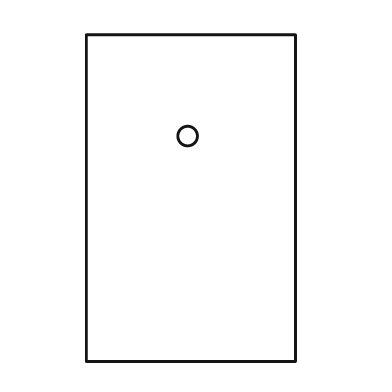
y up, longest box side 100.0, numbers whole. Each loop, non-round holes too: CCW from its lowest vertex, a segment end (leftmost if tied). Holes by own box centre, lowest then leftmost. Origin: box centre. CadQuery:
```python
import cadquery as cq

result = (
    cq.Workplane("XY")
    .moveTo(-32.0, -50.0)
    .lineTo(32.0, -50.0)
    .lineTo(32.0, 50.0)
    .lineTo(-32.0, 50.0)
    .close()
    .moveTo(-1.0, 19.0)
    .circle(3.0)
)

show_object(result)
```